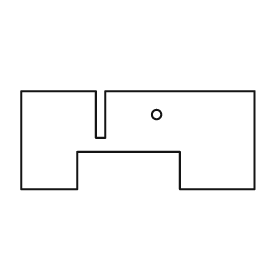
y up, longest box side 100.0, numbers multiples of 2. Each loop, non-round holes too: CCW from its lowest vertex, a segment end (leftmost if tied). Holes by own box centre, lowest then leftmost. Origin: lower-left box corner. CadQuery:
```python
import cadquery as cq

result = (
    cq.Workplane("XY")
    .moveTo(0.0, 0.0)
    .lineTo(24.0, 0.0)
    .lineTo(24.0, 16.0)
    .lineTo(68.0, 16.0)
    .lineTo(68.0, 0.0)
    .lineTo(100.0, 0.0)
    .lineTo(100.0, 42.0)
    .lineTo(36.0, 42.0)
    .lineTo(36.0, 22.0)
    .lineTo(32.0, 22.0)
    .lineTo(32.0, 42.0)
    .lineTo(0.0, 42.0)
    .close()
    .moveTo(58.0, 32.0)
    .circle(2.0)
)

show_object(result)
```